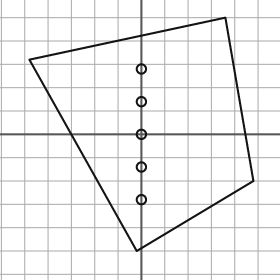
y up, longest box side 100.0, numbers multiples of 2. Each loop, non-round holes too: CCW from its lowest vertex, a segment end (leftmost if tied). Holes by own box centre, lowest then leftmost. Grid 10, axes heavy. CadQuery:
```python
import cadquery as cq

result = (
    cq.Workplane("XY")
    .moveTo(-2.0, -50.0)
    .lineTo(48.0, -20.0)
    .lineTo(36.0, 50.0)
    .lineTo(-48.0, 32.0)
    .close()
    .moveTo(0.0, -28.0)
    .circle(2.0)
    .moveTo(0.0, -14.0)
    .circle(2.0)
    .moveTo(0.0, 0.0)
    .circle(2.0)
    .moveTo(0.0, 14.0)
    .circle(2.0)
    .moveTo(0.0, 28.0)
    .circle(2.0)
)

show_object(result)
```